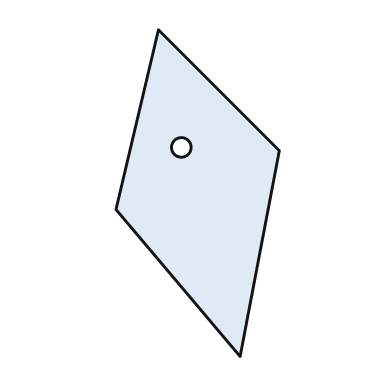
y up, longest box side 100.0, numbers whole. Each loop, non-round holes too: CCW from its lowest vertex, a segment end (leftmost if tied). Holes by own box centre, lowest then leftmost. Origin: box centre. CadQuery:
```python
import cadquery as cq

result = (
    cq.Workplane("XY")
    .moveTo(13.0, -50.0)
    .lineTo(25.0, 13.0)
    .lineTo(-12.0, 50.0)
    .lineTo(-25.0, -5.0)
    .close()
    .moveTo(-5.0, 14.0)
    .circle(3.0)
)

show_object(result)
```